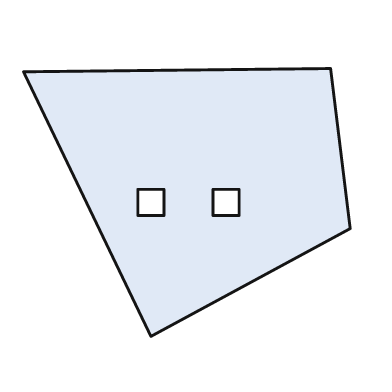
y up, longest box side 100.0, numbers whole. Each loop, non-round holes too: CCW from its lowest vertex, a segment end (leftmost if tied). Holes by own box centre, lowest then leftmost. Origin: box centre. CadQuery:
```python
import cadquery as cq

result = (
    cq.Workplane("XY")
    .moveTo(-11.0, -41.0)
    .lineTo(50.0, -8.0)
    .lineTo(44.0, 41.0)
    .lineTo(-50.0, 40.0)
    .close()
    .moveTo(-15.0, -4.0)
    .lineTo(-7.0, -4.0)
    .lineTo(-7.0, 4.0)
    .lineTo(-15.0, 4.0)
    .close()
    .moveTo(8.0, -4.0)
    .lineTo(16.0, -4.0)
    .lineTo(16.0, 4.0)
    .lineTo(8.0, 4.0)
    .close()
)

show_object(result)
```